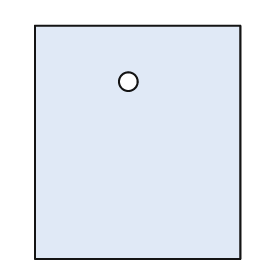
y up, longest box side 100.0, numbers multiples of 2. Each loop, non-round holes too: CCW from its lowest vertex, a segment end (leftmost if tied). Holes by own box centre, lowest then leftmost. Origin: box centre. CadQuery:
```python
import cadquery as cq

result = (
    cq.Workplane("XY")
    .moveTo(-44.0, -50.0)
    .lineTo(44.0, -50.0)
    .lineTo(44.0, 50.0)
    .lineTo(-44.0, 50.0)
    .close()
    .moveTo(-4.0, 26.0)
    .circle(4.0)
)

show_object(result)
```